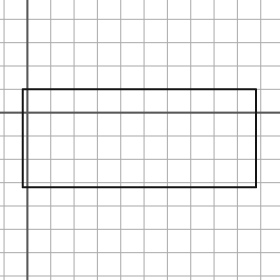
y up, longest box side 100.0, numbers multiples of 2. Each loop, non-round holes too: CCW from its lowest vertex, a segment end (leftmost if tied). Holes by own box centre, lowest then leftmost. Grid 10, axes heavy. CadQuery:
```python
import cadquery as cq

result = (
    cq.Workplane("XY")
    .moveTo(-2.0, -32.0)
    .lineTo(98.0, -32.0)
    .lineTo(98.0, 10.0)
    .lineTo(-2.0, 10.0)
    .close()
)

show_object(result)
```